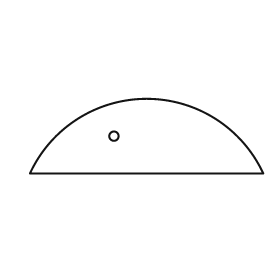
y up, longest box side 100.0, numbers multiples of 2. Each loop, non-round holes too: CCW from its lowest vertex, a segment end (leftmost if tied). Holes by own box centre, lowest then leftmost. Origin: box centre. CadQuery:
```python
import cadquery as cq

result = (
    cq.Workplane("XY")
    .moveTo(-50.0, -16.0)
    .lineTo(50.0, -16.0)
    .threePointArc((0.0, 16.0), (-50.0, -16.0))
    .close()
    .moveTo(-14.0, 0.0)
    .circle(2.0)
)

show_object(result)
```